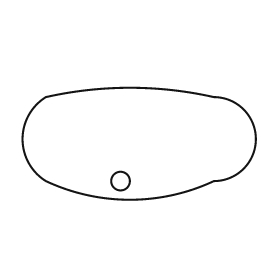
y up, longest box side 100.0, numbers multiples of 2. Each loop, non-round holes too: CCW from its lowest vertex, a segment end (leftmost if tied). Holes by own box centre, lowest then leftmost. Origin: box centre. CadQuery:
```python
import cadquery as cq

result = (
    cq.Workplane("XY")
    .moveTo(-40.0, -16.0)
    .threePointArc((-4.0, -24.0), (32.0, -16.0))
    .threePointArc((50.0, 2.0), (32.0, 20.0))
    .threePointArc((-4.0, 24.0), (-40.0, 20.0))
    .threePointArc((-50.0, 2.0), (-40.0, -16.0))
    .close()
    .moveTo(-8.0, -16.0)
    .circle(4.0)
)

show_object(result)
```